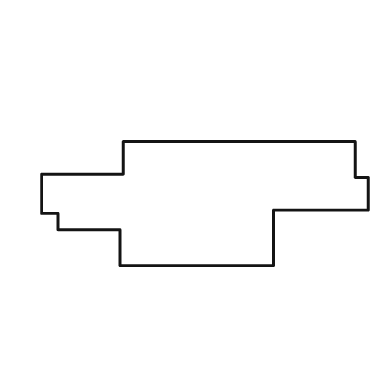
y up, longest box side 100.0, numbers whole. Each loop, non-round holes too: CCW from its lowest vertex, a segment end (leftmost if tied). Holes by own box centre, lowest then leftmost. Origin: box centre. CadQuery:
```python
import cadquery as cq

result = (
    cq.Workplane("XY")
    .moveTo(-26.0, -19.0)
    .lineTo(21.0, -19.0)
    .lineTo(21.0, -2.0)
    .lineTo(50.0, -2.0)
    .lineTo(50.0, 8.0)
    .lineTo(46.0, 8.0)
    .lineTo(46.0, 19.0)
    .lineTo(-25.0, 19.0)
    .lineTo(-25.0, 9.0)
    .lineTo(-50.0, 9.0)
    .lineTo(-50.0, -3.0)
    .lineTo(-45.0, -3.0)
    .lineTo(-45.0, -8.0)
    .lineTo(-26.0, -8.0)
    .close()
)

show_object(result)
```